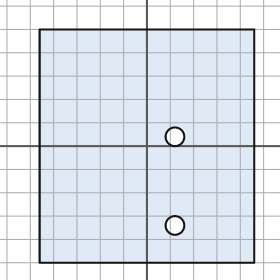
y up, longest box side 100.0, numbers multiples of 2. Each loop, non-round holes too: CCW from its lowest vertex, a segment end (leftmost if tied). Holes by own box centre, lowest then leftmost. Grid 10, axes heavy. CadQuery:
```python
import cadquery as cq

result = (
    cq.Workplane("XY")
    .moveTo(-46.0, -50.0)
    .lineTo(46.0, -50.0)
    .lineTo(46.0, 50.0)
    .lineTo(-46.0, 50.0)
    .close()
    .moveTo(12.0, -34.0)
    .circle(4.0)
    .moveTo(12.0, 4.0)
    .circle(4.0)
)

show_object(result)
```